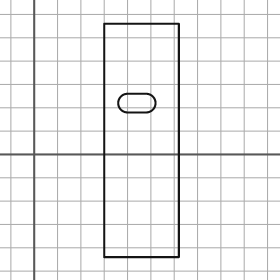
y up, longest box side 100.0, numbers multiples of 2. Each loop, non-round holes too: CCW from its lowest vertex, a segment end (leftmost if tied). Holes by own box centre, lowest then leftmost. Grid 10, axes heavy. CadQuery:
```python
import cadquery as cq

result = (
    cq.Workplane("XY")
    .moveTo(30.0, -44.0)
    .lineTo(62.0, -44.0)
    .lineTo(62.0, 56.0)
    .lineTo(30.0, 56.0)
    .close()
    .moveTo(40.0, 18.0)
    .lineTo(48.0, 18.0)
    .threePointArc((52.0, 22.0), (48.0, 26.0))
    .lineTo(40.0, 26.0)
    .threePointArc((36.0, 22.0), (40.0, 18.0))
    .close()
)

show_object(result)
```